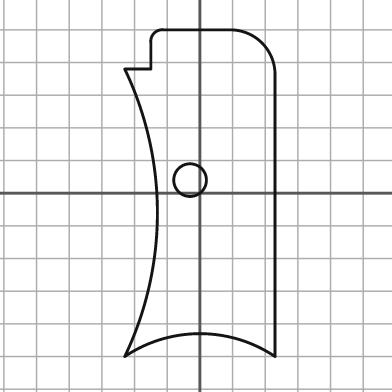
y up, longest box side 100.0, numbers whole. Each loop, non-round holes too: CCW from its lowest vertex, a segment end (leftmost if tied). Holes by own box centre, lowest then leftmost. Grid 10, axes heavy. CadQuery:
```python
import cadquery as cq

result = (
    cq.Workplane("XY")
    .moveTo(-23.0, -50.0)
    .threePointArc((0.0, -43.0), (23.0, -50.0))
    .lineTo(23.0, 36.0)
    .threePointArc((19.0, 46.0), (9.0, 50.0))
    .lineTo(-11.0, 50.0)
    .threePointArc((-14.0, 49.0), (-15.0, 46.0))
    .lineTo(-15.0, 38.0)
    .lineTo(-23.0, 38.0)
    .threePointArc((-13.0, -6.0), (-23.0, -50.0))
    .close()
    .moveTo(-3.0, 4.0)
    .circle(5.0)
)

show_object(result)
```